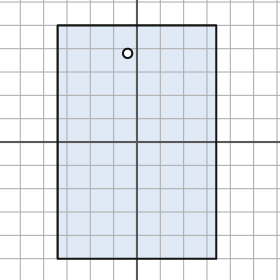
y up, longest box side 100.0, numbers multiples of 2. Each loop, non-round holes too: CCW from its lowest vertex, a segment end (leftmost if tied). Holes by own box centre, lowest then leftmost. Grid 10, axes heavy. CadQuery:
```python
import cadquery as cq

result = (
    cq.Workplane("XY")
    .moveTo(-34.0, -50.0)
    .lineTo(34.0, -50.0)
    .lineTo(34.0, 50.0)
    .lineTo(-34.0, 50.0)
    .close()
    .moveTo(-4.0, 38.0)
    .circle(2.0)
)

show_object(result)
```